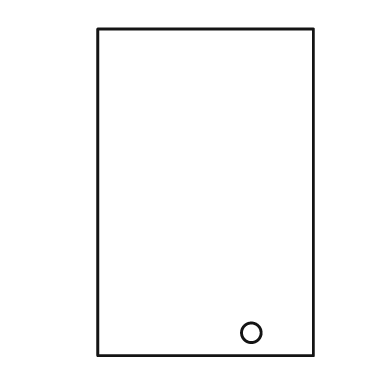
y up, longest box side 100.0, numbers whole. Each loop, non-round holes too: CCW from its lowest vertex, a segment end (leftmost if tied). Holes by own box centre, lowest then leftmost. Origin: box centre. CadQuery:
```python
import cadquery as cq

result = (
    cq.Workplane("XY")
    .moveTo(-33.0, -50.0)
    .lineTo(33.0, -50.0)
    .lineTo(33.0, 50.0)
    .lineTo(-33.0, 50.0)
    .close()
    .moveTo(14.0, -43.0)
    .circle(3.0)
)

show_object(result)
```